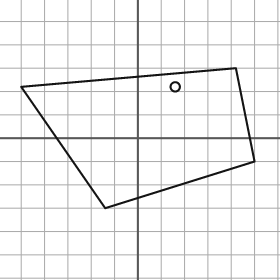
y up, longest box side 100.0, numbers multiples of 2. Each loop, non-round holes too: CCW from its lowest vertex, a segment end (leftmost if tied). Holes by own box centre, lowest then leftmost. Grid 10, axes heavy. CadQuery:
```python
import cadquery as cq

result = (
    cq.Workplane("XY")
    .moveTo(-14.0, -30.0)
    .lineTo(50.0, -10.0)
    .lineTo(42.0, 30.0)
    .lineTo(-50.0, 22.0)
    .close()
    .moveTo(16.0, 22.0)
    .circle(2.0)
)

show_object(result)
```